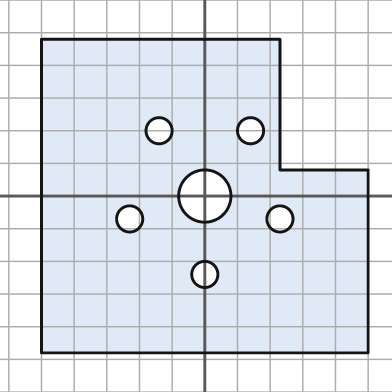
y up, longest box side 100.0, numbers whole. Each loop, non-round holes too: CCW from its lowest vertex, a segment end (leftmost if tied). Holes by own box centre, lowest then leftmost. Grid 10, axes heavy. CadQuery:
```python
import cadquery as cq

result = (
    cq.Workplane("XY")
    .moveTo(-50.0, -48.0)
    .lineTo(50.0, -48.0)
    .lineTo(50.0, 8.0)
    .lineTo(23.0, 8.0)
    .lineTo(23.0, 48.0)
    .lineTo(-50.0, 48.0)
    .close()
    .moveTo(0.0, -24.0)
    .circle(4.0)
    .moveTo(-23.0, -7.0)
    .circle(4.0)
    .moveTo(23.0, -7.0)
    .circle(4.0)
    .moveTo(0.0, 0.0)
    .circle(8.0)
    .moveTo(-14.0, 20.0)
    .circle(4.0)
    .moveTo(14.0, 20.0)
    .circle(4.0)
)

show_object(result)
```